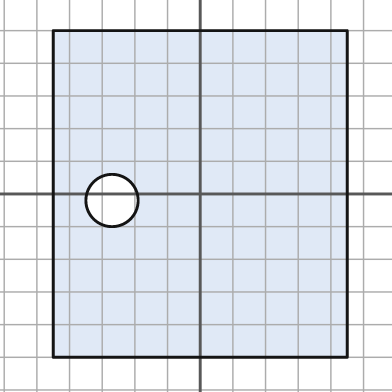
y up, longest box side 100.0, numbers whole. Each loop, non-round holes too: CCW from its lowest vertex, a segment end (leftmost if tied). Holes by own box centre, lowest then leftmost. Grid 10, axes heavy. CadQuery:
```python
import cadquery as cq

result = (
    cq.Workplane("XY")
    .moveTo(-45.0, -50.0)
    .lineTo(45.0, -50.0)
    .lineTo(45.0, 50.0)
    .lineTo(-45.0, 50.0)
    .close()
    .moveTo(-27.0, -2.0)
    .circle(8.0)
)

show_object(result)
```